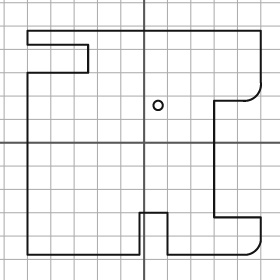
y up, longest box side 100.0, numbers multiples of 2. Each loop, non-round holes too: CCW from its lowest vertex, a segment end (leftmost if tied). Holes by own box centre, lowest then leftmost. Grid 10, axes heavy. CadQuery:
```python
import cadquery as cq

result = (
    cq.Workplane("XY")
    .moveTo(-50.0, -48.0)
    .lineTo(-2.0, -48.0)
    .lineTo(-2.0, -30.0)
    .lineTo(10.0, -30.0)
    .lineTo(10.0, -48.0)
    .lineTo(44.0, -48.0)
    .threePointArc((48.0, -46.0), (50.0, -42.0))
    .lineTo(50.0, -32.0)
    .lineTo(30.0, -32.0)
    .lineTo(30.0, 18.0)
    .lineTo(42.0, 18.0)
    .threePointArc((48.0, 20.0), (50.0, 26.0))
    .lineTo(50.0, 48.0)
    .lineTo(-50.0, 48.0)
    .lineTo(-50.0, 42.0)
    .lineTo(-24.0, 42.0)
    .lineTo(-24.0, 30.0)
    .lineTo(-50.0, 30.0)
    .close()
    .moveTo(6.0, 16.0)
    .circle(2.0)
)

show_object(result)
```